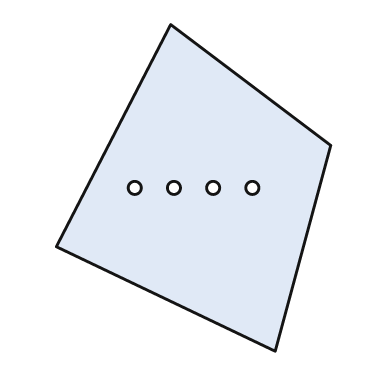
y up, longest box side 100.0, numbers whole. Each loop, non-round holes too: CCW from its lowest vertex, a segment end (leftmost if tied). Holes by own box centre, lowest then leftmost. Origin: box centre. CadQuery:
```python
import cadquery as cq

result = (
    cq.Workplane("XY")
    .moveTo(25.0, -50.0)
    .lineTo(42.0, 13.0)
    .lineTo(-7.0, 50.0)
    .lineTo(-42.0, -18.0)
    .close()
    .moveTo(-18.0, 0.0)
    .circle(2.0)
    .moveTo(-6.0, 0.0)
    .circle(2.0)
    .moveTo(6.0, 0.0)
    .circle(2.0)
    .moveTo(18.0, 0.0)
    .circle(2.0)
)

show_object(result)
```